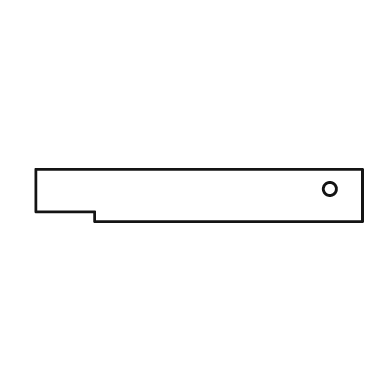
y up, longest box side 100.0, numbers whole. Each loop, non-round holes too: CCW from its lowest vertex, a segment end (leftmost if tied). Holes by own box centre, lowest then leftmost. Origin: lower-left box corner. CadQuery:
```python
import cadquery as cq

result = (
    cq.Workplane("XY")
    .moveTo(18.0, 0.0)
    .lineTo(100.0, 0.0)
    .lineTo(100.0, 16.0)
    .lineTo(0.0, 16.0)
    .lineTo(0.0, 3.0)
    .lineTo(18.0, 3.0)
    .close()
    .moveTo(90.0, 10.0)
    .circle(2.0)
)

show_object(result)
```